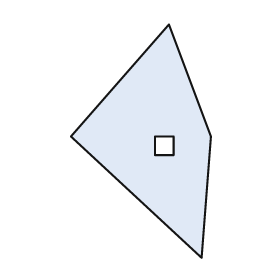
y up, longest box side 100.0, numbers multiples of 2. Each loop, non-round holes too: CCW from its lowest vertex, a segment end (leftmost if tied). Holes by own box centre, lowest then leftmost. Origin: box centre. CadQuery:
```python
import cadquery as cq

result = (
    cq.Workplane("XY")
    .moveTo(26.0, -50.0)
    .lineTo(30.0, 2.0)
    .lineTo(12.0, 50.0)
    .lineTo(-30.0, 2.0)
    .close()
    .moveTo(6.0, -6.0)
    .lineTo(14.0, -6.0)
    .lineTo(14.0, 2.0)
    .lineTo(6.0, 2.0)
    .close()
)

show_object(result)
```